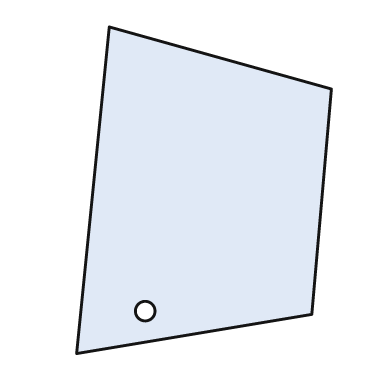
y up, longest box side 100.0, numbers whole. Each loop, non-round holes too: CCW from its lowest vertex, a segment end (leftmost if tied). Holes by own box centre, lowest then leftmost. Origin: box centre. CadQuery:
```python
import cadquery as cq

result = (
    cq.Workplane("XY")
    .moveTo(-39.0, -50.0)
    .lineTo(33.0, -38.0)
    .lineTo(39.0, 31.0)
    .lineTo(-29.0, 50.0)
    .close()
    .moveTo(-18.0, -37.0)
    .circle(3.0)
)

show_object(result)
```